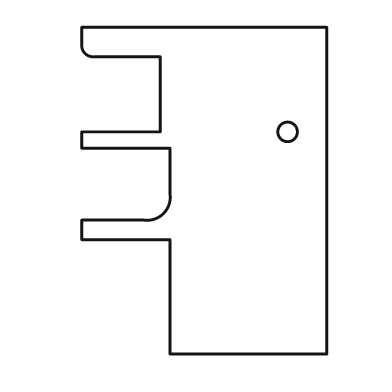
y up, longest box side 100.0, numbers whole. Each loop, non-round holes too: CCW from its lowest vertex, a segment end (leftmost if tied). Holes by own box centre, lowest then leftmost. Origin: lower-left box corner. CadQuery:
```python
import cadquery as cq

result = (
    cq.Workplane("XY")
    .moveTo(27.0, 0.0)
    .lineTo(75.0, 0.0)
    .lineTo(75.0, 100.0)
    .lineTo(0.0, 100.0)
    .lineTo(0.0, 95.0)
    .threePointArc((1.0, 92.0), (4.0, 91.0))
    .lineTo(24.0, 91.0)
    .lineTo(24.0, 68.0)
    .lineTo(0.0, 68.0)
    .lineTo(0.0, 63.0)
    .lineTo(27.0, 63.0)
    .lineTo(27.0, 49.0)
    .threePointArc((25.0, 43.0), (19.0, 41.0))
    .lineTo(0.0, 41.0)
    .lineTo(0.0, 35.0)
    .lineTo(27.0, 35.0)
    .close()
    .moveTo(63.0, 68.0)
    .circle(3.0)
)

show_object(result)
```